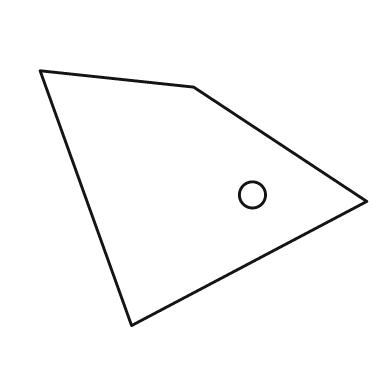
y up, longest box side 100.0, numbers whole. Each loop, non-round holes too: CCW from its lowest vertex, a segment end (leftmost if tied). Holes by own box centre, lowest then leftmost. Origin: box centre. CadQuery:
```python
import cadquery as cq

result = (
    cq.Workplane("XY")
    .moveTo(-22.0, -39.0)
    .lineTo(50.0, -1.0)
    .lineTo(-3.0, 34.0)
    .lineTo(-50.0, 39.0)
    .close()
    .moveTo(15.0, 1.0)
    .circle(4.0)
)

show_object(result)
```